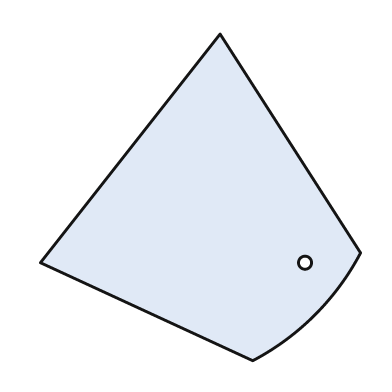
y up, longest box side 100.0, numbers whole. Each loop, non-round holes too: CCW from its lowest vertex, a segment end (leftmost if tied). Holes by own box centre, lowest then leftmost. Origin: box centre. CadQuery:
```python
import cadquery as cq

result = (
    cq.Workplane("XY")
    .moveTo(16.0, -50.0)
    .threePointArc((35.0, -36.0), (49.0, -17.0))
    .lineTo(6.0, 50.0)
    .lineTo(-49.0, -20.0)
    .close()
    .moveTo(32.0, -20.0)
    .circle(2.0)
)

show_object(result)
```